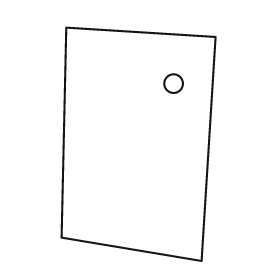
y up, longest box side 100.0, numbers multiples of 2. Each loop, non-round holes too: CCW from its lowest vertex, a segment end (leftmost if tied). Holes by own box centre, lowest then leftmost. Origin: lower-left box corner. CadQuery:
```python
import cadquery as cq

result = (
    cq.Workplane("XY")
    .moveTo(60.0, 0.0)
    .lineTo(66.0, 96.0)
    .lineTo(2.0, 100.0)
    .lineTo(0.0, 10.0)
    .close()
    .moveTo(48.0, 76.0)
    .circle(4.0)
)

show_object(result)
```